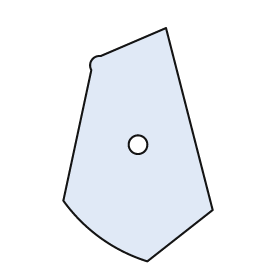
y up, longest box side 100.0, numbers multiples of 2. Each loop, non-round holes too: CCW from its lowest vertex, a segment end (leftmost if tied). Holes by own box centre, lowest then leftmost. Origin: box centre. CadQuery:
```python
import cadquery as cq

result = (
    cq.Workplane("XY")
    .moveTo(4.0, -50.0)
    .lineTo(32.0, -28.0)
    .lineTo(12.0, 50.0)
    .lineTo(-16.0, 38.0)
    .threePointArc((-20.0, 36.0), (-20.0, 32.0))
    .lineTo(-32.0, -24.0)
    .threePointArc((-16.0, -40.0), (4.0, -50.0))
    .close()
    .moveTo(0.0, 0.0)
    .circle(4.0)
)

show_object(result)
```